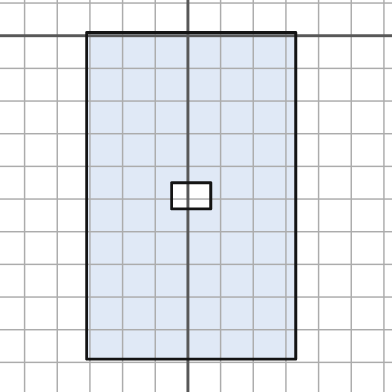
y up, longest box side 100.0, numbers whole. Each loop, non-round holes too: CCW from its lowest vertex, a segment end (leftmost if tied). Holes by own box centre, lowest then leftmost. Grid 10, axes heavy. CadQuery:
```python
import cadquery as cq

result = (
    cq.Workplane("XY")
    .moveTo(-31.0, -99.0)
    .lineTo(33.0, -99.0)
    .lineTo(33.0, 1.0)
    .lineTo(-31.0, 1.0)
    .close()
    .moveTo(-5.0, -53.0)
    .lineTo(7.0, -53.0)
    .lineTo(7.0, -45.0)
    .lineTo(-5.0, -45.0)
    .close()
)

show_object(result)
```